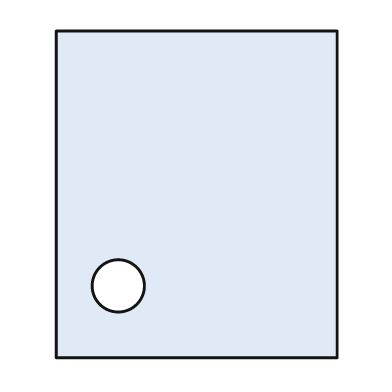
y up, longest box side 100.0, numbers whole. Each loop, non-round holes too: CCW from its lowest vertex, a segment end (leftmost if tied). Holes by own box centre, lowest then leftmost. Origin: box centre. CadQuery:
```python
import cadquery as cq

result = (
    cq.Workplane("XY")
    .moveTo(-43.0, -50.0)
    .lineTo(43.0, -50.0)
    .lineTo(43.0, 50.0)
    .lineTo(-43.0, 50.0)
    .close()
    .moveTo(-24.0, -28.0)
    .circle(8.0)
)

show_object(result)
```